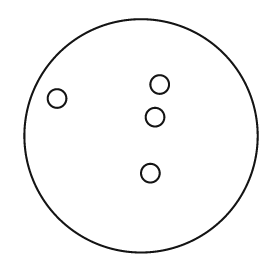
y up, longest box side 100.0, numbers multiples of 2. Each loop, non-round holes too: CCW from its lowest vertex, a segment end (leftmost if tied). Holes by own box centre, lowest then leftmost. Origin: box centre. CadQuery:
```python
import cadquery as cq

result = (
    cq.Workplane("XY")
    .moveTo(0.0, 0.0)
    .circle(50.0)
    .moveTo(4.0, -16.0)
    .circle(4.0)
    .moveTo(6.0, 8.0)
    .circle(4.0)
    .moveTo(-36.0, 16.0)
    .circle(4.0)
    .moveTo(8.0, 22.0)
    .circle(4.0)
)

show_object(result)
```